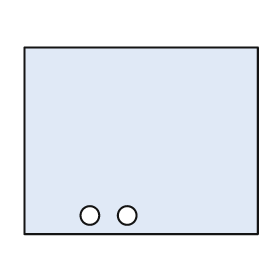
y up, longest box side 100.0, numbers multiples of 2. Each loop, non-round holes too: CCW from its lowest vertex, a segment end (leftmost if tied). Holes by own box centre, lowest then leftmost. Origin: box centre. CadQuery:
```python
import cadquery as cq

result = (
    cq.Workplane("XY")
    .moveTo(-50.0, -40.0)
    .lineTo(50.0, -40.0)
    .lineTo(50.0, 40.0)
    .lineTo(-50.0, 40.0)
    .close()
    .moveTo(-22.0, -32.0)
    .circle(4.0)
    .moveTo(-6.0, -32.0)
    .circle(4.0)
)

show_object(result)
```